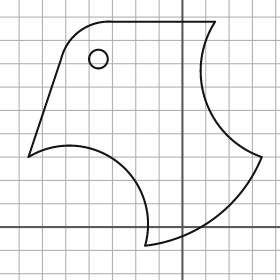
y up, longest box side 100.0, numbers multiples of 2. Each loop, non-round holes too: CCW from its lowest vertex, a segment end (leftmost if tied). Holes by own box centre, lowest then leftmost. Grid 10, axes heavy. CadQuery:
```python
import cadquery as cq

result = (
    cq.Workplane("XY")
    .moveTo(-16.0, -8.0)
    .threePointArc((14.0, 4.0), (34.0, 30.0))
    .threePointArc((10.0, 54.0), (14.0, 88.0))
    .lineTo(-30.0, 88.0)
    .threePointArc((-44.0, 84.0), (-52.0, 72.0))
    .lineTo(-66.0, 30.0)
    .threePointArc((-28.0, 28.0), (-16.0, -8.0))
    .close()
    .moveTo(-36.0, 72.0)
    .circle(4.0)
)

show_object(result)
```